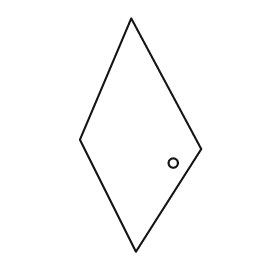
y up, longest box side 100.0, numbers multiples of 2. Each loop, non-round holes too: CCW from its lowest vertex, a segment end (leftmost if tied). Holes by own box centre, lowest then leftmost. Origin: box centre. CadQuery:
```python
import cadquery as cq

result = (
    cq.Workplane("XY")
    .moveTo(-2.0, -50.0)
    .lineTo(26.0, -6.0)
    .lineTo(-4.0, 50.0)
    .lineTo(-26.0, -2.0)
    .close()
    .moveTo(14.0, -12.0)
    .circle(2.0)
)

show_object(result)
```